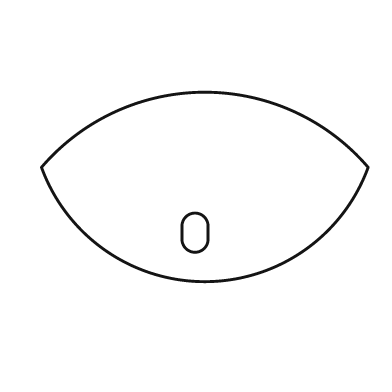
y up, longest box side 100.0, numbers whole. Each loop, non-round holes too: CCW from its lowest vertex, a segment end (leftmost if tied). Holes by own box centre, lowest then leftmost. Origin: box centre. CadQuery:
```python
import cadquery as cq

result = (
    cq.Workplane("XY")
    .moveTo(-50.0, 6.0)
    .threePointArc((0.0, -29.0), (50.0, 6.0))
    .threePointArc((0.0, 29.0), (-50.0, 6.0))
    .close()
    .moveTo(-7.0, -16.0)
    .threePointArc((-3.0, -20.0), (1.0, -16.0))
    .lineTo(1.0, -12.0)
    .threePointArc((-3.0, -8.0), (-7.0, -12.0))
    .close()
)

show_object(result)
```